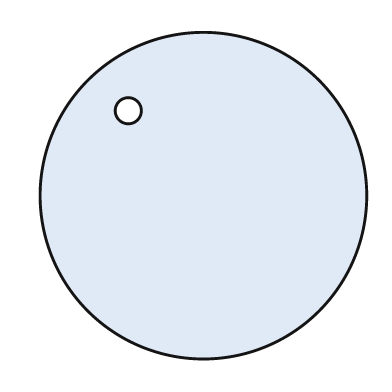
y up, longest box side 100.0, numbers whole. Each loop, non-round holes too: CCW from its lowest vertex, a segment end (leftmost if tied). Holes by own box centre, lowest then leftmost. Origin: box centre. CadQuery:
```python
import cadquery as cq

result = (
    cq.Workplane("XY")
    .moveTo(0.0, 0.0)
    .circle(50.0)
    .moveTo(-23.0, 26.0)
    .circle(4.0)
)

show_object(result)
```